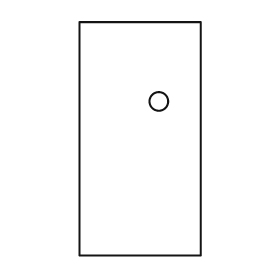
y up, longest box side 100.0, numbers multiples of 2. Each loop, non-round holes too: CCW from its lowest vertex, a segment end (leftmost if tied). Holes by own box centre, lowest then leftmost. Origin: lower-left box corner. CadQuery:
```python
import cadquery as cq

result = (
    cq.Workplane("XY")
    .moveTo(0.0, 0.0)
    .lineTo(52.0, 0.0)
    .lineTo(52.0, 100.0)
    .lineTo(0.0, 100.0)
    .close()
    .moveTo(34.0, 66.0)
    .circle(4.0)
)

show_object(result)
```